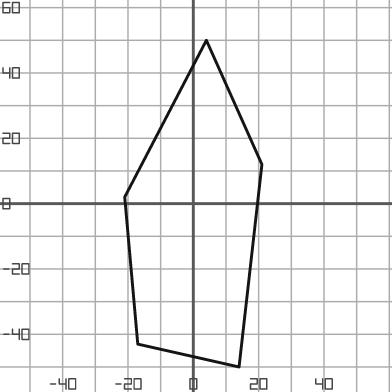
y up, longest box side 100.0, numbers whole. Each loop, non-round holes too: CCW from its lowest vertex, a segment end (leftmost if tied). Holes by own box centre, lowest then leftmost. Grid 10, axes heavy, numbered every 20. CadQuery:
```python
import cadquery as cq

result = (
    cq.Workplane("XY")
    .moveTo(14.0, -50.0)
    .lineTo(21.0, 12.0)
    .lineTo(4.0, 50.0)
    .lineTo(-21.0, 2.0)
    .lineTo(-17.0, -43.0)
    .close()
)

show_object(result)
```